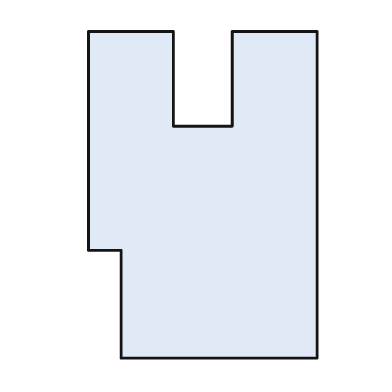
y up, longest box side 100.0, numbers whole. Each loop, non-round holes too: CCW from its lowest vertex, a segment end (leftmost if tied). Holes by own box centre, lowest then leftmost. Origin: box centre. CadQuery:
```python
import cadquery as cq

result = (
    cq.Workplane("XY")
    .moveTo(-25.0, -50.0)
    .lineTo(35.0, -50.0)
    .lineTo(35.0, 50.0)
    .lineTo(9.0, 50.0)
    .lineTo(9.0, 21.0)
    .lineTo(-9.0, 21.0)
    .lineTo(-9.0, 50.0)
    .lineTo(-35.0, 50.0)
    .lineTo(-35.0, -17.0)
    .lineTo(-25.0, -17.0)
    .close()
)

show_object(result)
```